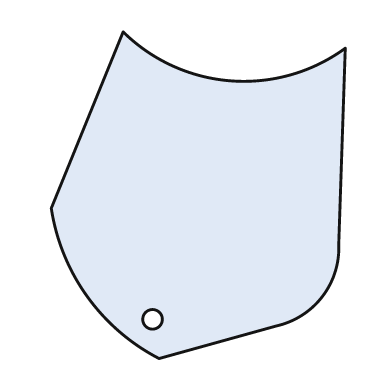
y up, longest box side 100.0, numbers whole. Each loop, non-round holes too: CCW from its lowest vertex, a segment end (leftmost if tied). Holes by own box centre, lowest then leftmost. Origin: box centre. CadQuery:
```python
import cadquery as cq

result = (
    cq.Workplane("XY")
    .moveTo(-12.0, -50.0)
    .lineTo(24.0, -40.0)
    .threePointArc((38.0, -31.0), (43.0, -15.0))
    .lineTo(45.0, 45.0)
    .threePointArc((10.0, 35.0), (-23.0, 50.0))
    .lineTo(-45.0, -4.0)
    .threePointArc((-34.0, -31.0), (-12.0, -50.0))
    .close()
    .moveTo(-14.0, -38.0)
    .circle(3.0)
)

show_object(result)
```